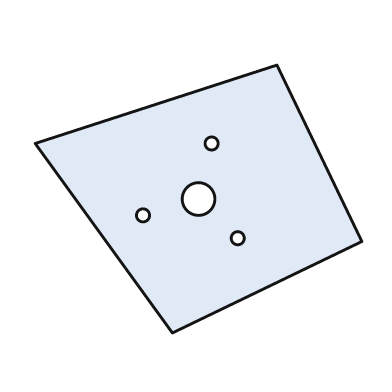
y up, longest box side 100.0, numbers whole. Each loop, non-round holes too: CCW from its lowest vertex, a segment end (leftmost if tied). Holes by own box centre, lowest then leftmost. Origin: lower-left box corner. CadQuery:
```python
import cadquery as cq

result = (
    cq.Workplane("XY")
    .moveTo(42.0, 0.0)
    .lineTo(100.0, 28.0)
    .lineTo(74.0, 82.0)
    .lineTo(0.0, 58.0)
    .close()
    .moveTo(62.0, 29.0)
    .circle(2.0)
    .moveTo(33.0, 36.0)
    .circle(2.0)
    .moveTo(50.0, 41.0)
    .circle(5.0)
    .moveTo(54.0, 58.0)
    .circle(2.0)
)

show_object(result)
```